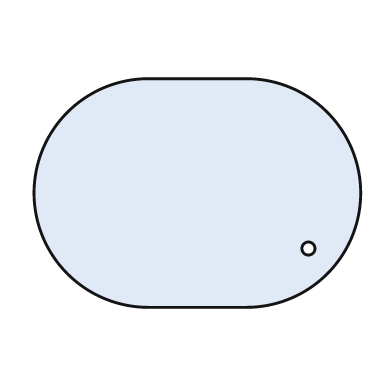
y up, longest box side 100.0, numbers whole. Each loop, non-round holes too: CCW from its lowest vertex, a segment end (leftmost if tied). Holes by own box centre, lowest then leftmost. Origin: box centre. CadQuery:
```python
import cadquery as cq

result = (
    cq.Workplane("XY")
    .moveTo(-15.0, -35.0)
    .lineTo(15.0, -35.0)
    .threePointArc((50.0, 0.0), (15.0, 35.0))
    .lineTo(-15.0, 35.0)
    .threePointArc((-50.0, 0.0), (-15.0, -35.0))
    .close()
    .moveTo(34.0, -17.0)
    .circle(2.0)
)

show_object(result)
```